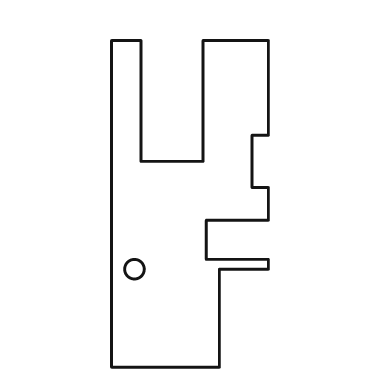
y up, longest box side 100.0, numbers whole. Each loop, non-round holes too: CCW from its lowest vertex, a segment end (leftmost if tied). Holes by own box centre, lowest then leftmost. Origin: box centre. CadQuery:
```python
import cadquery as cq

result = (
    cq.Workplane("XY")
    .moveTo(-24.0, -50.0)
    .lineTo(9.0, -50.0)
    .lineTo(9.0, -20.0)
    .lineTo(24.0, -20.0)
    .lineTo(24.0, -17.0)
    .lineTo(5.0, -17.0)
    .lineTo(5.0, -5.0)
    .lineTo(24.0, -5.0)
    .lineTo(24.0, 5.0)
    .lineTo(19.0, 5.0)
    .lineTo(19.0, 21.0)
    .lineTo(24.0, 21.0)
    .lineTo(24.0, 50.0)
    .lineTo(4.0, 50.0)
    .lineTo(4.0, 13.0)
    .lineTo(-15.0, 13.0)
    .lineTo(-15.0, 50.0)
    .lineTo(-24.0, 50.0)
    .close()
    .moveTo(-17.0, -20.0)
    .circle(3.0)
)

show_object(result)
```